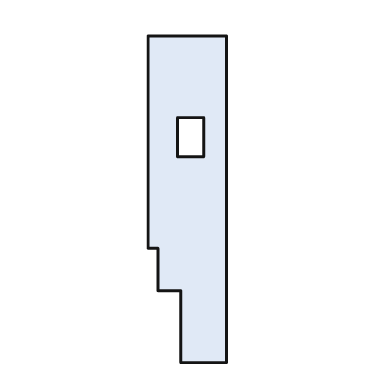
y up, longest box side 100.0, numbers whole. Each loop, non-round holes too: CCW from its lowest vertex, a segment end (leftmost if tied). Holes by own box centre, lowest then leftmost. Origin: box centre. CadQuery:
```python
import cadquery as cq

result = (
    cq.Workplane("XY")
    .moveTo(-2.0, -50.0)
    .lineTo(12.0, -50.0)
    .lineTo(12.0, 50.0)
    .lineTo(-12.0, 50.0)
    .lineTo(-12.0, -15.0)
    .lineTo(-9.0, -15.0)
    .lineTo(-9.0, -28.0)
    .lineTo(-2.0, -28.0)
    .close()
    .moveTo(-3.0, 13.0)
    .lineTo(5.0, 13.0)
    .lineTo(5.0, 25.0)
    .lineTo(-3.0, 25.0)
    .close()
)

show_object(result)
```